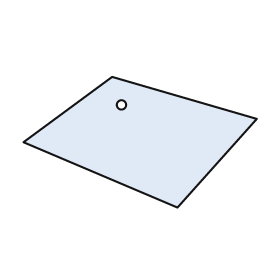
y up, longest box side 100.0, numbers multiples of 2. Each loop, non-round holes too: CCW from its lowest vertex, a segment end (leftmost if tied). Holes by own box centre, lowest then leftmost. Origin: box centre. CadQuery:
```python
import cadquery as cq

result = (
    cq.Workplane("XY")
    .moveTo(16.0, -28.0)
    .lineTo(50.0, 10.0)
    .lineTo(-12.0, 28.0)
    .lineTo(-50.0, 0.0)
    .close()
    .moveTo(-8.0, 16.0)
    .circle(2.0)
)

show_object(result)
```